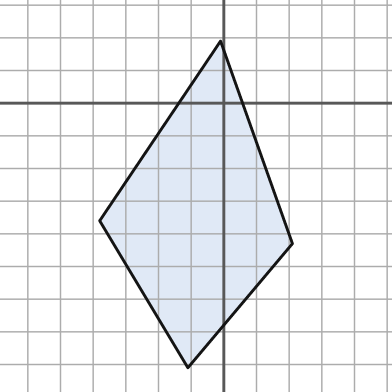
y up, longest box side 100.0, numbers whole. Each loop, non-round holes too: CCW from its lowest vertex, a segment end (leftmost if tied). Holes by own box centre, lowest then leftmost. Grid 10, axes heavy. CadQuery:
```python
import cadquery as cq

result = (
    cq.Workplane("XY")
    .moveTo(-11.0, -81.0)
    .lineTo(21.0, -43.0)
    .lineTo(-1.0, 19.0)
    .lineTo(-38.0, -36.0)
    .close()
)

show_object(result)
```